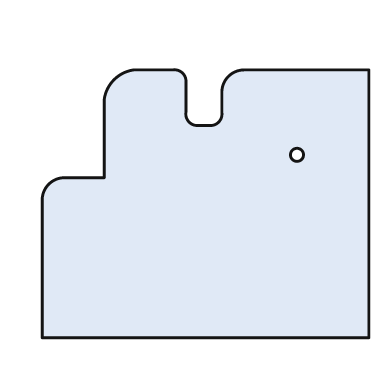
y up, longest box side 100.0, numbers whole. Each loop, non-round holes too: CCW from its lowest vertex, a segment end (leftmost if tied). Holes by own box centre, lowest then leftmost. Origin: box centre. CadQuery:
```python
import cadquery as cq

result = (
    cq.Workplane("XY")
    .moveTo(-50.0, -41.0)
    .lineTo(50.0, -41.0)
    .lineTo(50.0, 41.0)
    .lineTo(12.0, 41.0)
    .threePointArc((7.0, 39.0), (5.0, 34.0))
    .lineTo(5.0, 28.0)
    .threePointArc((4.0, 25.0), (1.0, 24.0))
    .lineTo(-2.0, 24.0)
    .threePointArc((-5.0, 25.0), (-6.0, 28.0))
    .lineTo(-6.0, 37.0)
    .threePointArc((-7.0, 40.0), (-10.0, 41.0))
    .lineTo(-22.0, 41.0)
    .threePointArc((-28.0, 38.0), (-31.0, 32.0))
    .lineTo(-31.0, 8.0)
    .lineTo(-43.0, 8.0)
    .threePointArc((-48.0, 6.0), (-50.0, 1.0))
    .close()
    .moveTo(28.0, 15.0)
    .circle(2.0)
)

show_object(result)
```